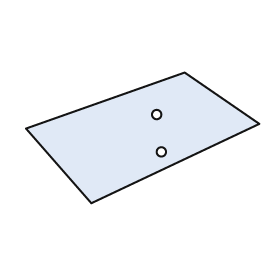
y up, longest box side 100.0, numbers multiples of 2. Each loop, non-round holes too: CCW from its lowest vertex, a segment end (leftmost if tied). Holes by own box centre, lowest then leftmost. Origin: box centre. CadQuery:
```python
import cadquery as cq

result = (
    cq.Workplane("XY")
    .moveTo(-22.0, -28.0)
    .lineTo(50.0, 6.0)
    .lineTo(18.0, 28.0)
    .lineTo(-50.0, 4.0)
    .close()
    .moveTo(8.0, -6.0)
    .circle(2.0)
    .moveTo(6.0, 10.0)
    .circle(2.0)
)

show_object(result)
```